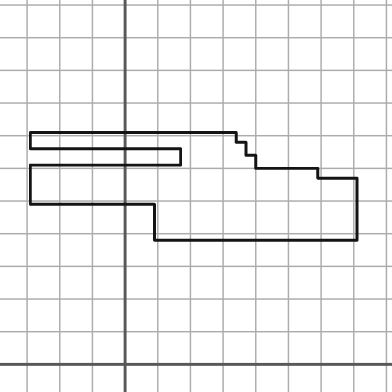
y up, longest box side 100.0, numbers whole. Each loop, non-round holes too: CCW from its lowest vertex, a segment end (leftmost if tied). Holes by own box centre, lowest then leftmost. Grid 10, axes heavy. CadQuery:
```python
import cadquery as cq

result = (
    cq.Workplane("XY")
    .moveTo(9.0, 38.0)
    .lineTo(71.0, 38.0)
    .lineTo(71.0, 57.0)
    .lineTo(59.0, 57.0)
    .lineTo(59.0, 60.0)
    .lineTo(40.0, 60.0)
    .lineTo(40.0, 64.0)
    .lineTo(37.0, 64.0)
    .lineTo(37.0, 68.0)
    .lineTo(34.0, 68.0)
    .lineTo(34.0, 71.0)
    .lineTo(-29.0, 71.0)
    .lineTo(-29.0, 66.0)
    .lineTo(17.0, 66.0)
    .lineTo(17.0, 61.0)
    .lineTo(-29.0, 61.0)
    .lineTo(-29.0, 49.0)
    .lineTo(9.0, 49.0)
    .close()
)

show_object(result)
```